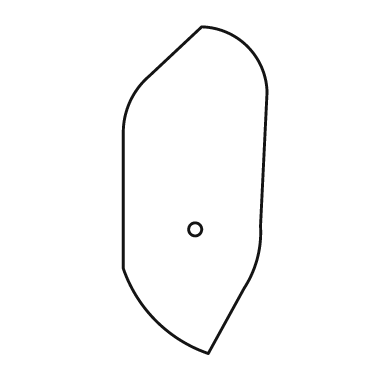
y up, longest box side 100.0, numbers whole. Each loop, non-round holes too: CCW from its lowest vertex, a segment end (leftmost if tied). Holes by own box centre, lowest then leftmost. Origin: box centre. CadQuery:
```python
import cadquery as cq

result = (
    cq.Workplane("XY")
    .moveTo(4.0, -50.0)
    .lineTo(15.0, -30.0)
    .threePointArc((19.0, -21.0), (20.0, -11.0))
    .lineTo(22.0, 30.0)
    .threePointArc((16.0, 44.0), (2.0, 50.0))
    .lineTo(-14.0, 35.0)
    .threePointArc((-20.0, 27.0), (-22.0, 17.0))
    .lineTo(-22.0, -24.0)
    .threePointArc((-12.0, -40.0), (4.0, -50.0))
    .close()
    .moveTo(0.0, -12.0)
    .circle(2.0)
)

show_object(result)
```